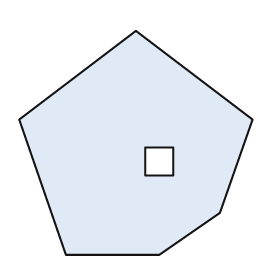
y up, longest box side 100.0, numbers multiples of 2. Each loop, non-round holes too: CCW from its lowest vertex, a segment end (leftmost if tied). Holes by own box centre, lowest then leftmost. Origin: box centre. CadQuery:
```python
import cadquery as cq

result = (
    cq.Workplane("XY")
    .moveTo(-30.0, -48.0)
    .lineTo(10.0, -48.0)
    .lineTo(36.0, -30.0)
    .lineTo(50.0, 10.0)
    .lineTo(0.0, 48.0)
    .lineTo(-50.0, 10.0)
    .close()
    .moveTo(4.0, -14.0)
    .lineTo(16.0, -14.0)
    .lineTo(16.0, -2.0)
    .lineTo(4.0, -2.0)
    .close()
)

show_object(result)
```